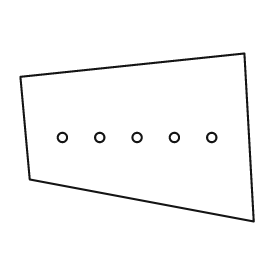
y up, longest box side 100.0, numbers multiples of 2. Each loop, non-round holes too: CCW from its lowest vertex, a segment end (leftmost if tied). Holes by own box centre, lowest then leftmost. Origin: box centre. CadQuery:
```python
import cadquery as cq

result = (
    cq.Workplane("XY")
    .moveTo(50.0, -36.0)
    .lineTo(46.0, 36.0)
    .lineTo(-50.0, 26.0)
    .lineTo(-46.0, -18.0)
    .close()
    .moveTo(-32.0, 0.0)
    .circle(2.0)
    .moveTo(-16.0, 0.0)
    .circle(2.0)
    .moveTo(0.0, 0.0)
    .circle(2.0)
    .moveTo(16.0, 0.0)
    .circle(2.0)
    .moveTo(32.0, 0.0)
    .circle(2.0)
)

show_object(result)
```